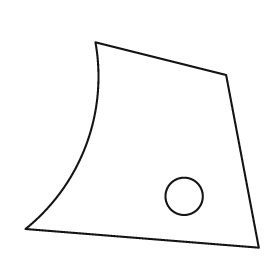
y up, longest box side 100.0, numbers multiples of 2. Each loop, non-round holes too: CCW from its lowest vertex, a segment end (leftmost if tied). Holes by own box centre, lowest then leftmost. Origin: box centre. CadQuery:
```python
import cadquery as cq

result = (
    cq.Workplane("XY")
    .moveTo(50.0, -44.0)
    .lineTo(36.0, 30.0)
    .lineTo(-20.0, 44.0)
    .threePointArc((-24.0, 0.0), (-50.0, -36.0))
    .close()
    .moveTo(18.0, -22.0)
    .circle(8.0)
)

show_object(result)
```